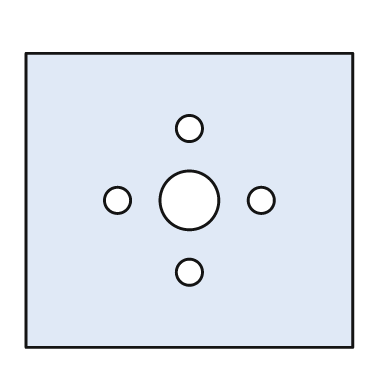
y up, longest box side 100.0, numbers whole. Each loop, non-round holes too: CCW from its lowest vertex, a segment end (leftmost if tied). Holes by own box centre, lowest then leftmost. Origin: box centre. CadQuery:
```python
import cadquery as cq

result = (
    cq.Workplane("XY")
    .moveTo(-50.0, -45.0)
    .lineTo(50.0, -45.0)
    .lineTo(50.0, 45.0)
    .lineTo(-50.0, 45.0)
    .close()
    .moveTo(0.0, -22.0)
    .circle(4.0)
    .moveTo(-22.0, 0.0)
    .circle(4.0)
    .moveTo(0.0, 0.0)
    .circle(9.0)
    .moveTo(22.0, 0.0)
    .circle(4.0)
    .moveTo(0.0, 22.0)
    .circle(4.0)
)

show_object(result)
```